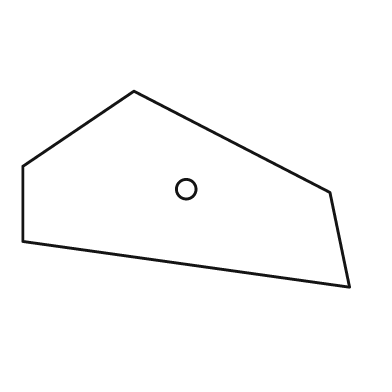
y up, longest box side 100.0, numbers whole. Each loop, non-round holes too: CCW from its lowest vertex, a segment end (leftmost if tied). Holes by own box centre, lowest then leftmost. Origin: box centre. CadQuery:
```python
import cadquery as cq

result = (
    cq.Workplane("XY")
    .moveTo(50.0, -30.0)
    .lineTo(44.0, -1.0)
    .lineTo(-16.0, 30.0)
    .lineTo(-50.0, 7.0)
    .lineTo(-50.0, -16.0)
    .close()
    .moveTo(0.0, 0.0)
    .circle(3.0)
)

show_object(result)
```